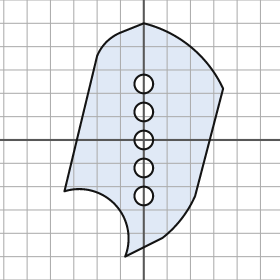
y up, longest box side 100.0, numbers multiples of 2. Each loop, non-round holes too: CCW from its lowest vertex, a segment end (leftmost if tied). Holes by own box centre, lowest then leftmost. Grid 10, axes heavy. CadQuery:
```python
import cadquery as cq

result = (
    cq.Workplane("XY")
    .moveTo(-8.0, -50.0)
    .lineTo(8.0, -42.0)
    .threePointArc((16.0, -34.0), (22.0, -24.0))
    .lineTo(34.0, 22.0)
    .threePointArc((20.0, 40.0), (0.0, 50.0))
    .lineTo(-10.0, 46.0)
    .threePointArc((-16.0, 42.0), (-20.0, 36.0))
    .lineTo(-34.0, -22.0)
    .threePointArc((-12.0, -28.0), (-8.0, -50.0))
    .close()
    .moveTo(0.0, -24.0)
    .circle(4.0)
    .moveTo(0.0, -12.0)
    .circle(4.0)
    .moveTo(0.0, 0.0)
    .circle(4.0)
    .moveTo(0.0, 12.0)
    .circle(4.0)
    .moveTo(0.0, 24.0)
    .circle(4.0)
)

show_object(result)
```